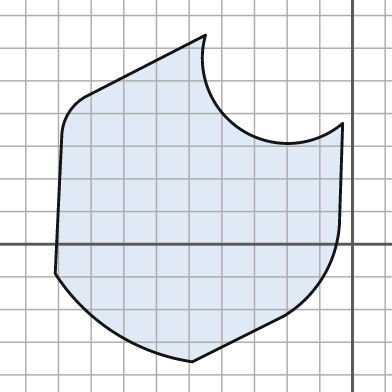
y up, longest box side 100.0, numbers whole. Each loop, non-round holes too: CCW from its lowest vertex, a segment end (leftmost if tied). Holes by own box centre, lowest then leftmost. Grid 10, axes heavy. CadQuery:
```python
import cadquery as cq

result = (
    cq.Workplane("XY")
    .moveTo(-49.0, -36.0)
    .lineTo(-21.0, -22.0)
    .threePointArc((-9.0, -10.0), (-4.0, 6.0))
    .lineTo(-3.0, 37.0)
    .threePointArc((-34.0, 35.0), (-45.0, 64.0))
    .lineTo(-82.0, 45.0)
    .threePointArc((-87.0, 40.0), (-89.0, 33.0))
    .lineTo(-91.0, -9.0)
    .threePointArc((-73.0, -27.0), (-49.0, -36.0))
    .close()
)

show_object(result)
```